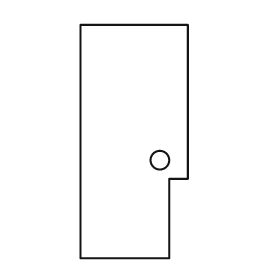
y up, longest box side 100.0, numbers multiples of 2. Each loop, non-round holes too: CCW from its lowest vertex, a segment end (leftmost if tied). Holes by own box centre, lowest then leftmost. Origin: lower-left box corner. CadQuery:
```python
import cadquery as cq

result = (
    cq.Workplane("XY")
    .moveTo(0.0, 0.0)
    .lineTo(38.0, 0.0)
    .lineTo(38.0, 34.0)
    .lineTo(46.0, 34.0)
    .lineTo(46.0, 100.0)
    .lineTo(0.0, 100.0)
    .close()
    .moveTo(34.0, 42.0)
    .circle(4.0)
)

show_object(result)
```